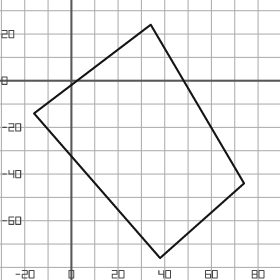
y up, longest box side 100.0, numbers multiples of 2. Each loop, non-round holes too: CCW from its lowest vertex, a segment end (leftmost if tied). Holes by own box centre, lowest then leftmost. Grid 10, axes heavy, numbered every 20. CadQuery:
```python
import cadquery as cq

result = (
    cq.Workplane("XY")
    .moveTo(38.0, -76.0)
    .lineTo(74.0, -44.0)
    .lineTo(34.0, 24.0)
    .lineTo(-16.0, -14.0)
    .close()
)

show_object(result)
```